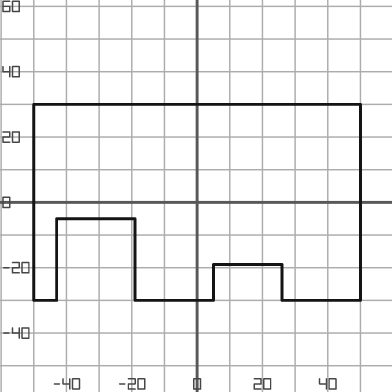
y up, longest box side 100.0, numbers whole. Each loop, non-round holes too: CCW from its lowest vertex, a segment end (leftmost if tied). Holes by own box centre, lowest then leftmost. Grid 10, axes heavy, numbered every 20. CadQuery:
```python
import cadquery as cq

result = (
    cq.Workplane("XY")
    .moveTo(-50.0, -30.0)
    .lineTo(-43.0, -30.0)
    .lineTo(-43.0, -5.0)
    .lineTo(-19.0, -5.0)
    .lineTo(-19.0, -30.0)
    .lineTo(5.0, -30.0)
    .lineTo(5.0, -19.0)
    .lineTo(26.0, -19.0)
    .lineTo(26.0, -30.0)
    .lineTo(50.0, -30.0)
    .lineTo(50.0, 30.0)
    .lineTo(-50.0, 30.0)
    .close()
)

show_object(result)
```